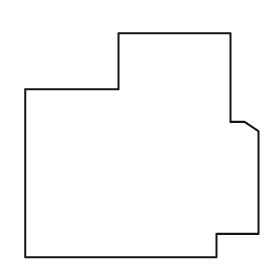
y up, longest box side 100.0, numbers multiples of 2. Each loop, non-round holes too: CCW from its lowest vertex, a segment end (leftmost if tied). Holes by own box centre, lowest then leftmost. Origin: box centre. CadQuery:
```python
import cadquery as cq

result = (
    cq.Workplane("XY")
    .moveTo(-50.0, -48.0)
    .lineTo(32.0, -48.0)
    .lineTo(32.0, -38.0)
    .lineTo(50.0, -38.0)
    .lineTo(50.0, 6.0)
    .lineTo(44.0, 10.0)
    .lineTo(38.0, 10.0)
    .lineTo(38.0, 48.0)
    .lineTo(-10.0, 48.0)
    .lineTo(-10.0, 24.0)
    .lineTo(-50.0, 24.0)
    .close()
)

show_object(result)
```